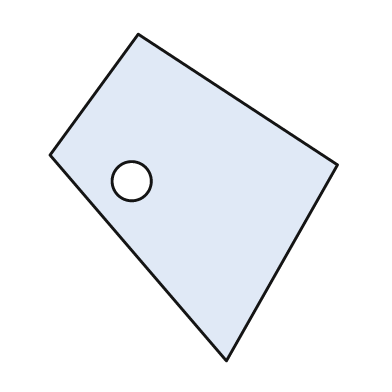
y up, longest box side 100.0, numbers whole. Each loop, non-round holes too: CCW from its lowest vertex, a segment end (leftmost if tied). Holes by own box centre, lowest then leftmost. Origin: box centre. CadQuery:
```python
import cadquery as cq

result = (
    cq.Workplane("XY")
    .moveTo(10.0, -50.0)
    .lineTo(44.0, 10.0)
    .lineTo(-17.0, 50.0)
    .lineTo(-44.0, 13.0)
    .close()
    .moveTo(-19.0, 5.0)
    .circle(6.0)
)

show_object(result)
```